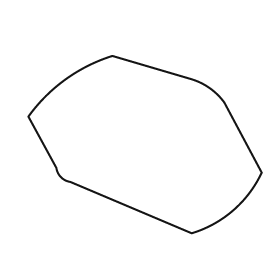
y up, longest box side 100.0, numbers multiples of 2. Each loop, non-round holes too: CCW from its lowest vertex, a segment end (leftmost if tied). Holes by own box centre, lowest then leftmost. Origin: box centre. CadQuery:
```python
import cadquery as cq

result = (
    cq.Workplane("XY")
    .moveTo(20.0, -38.0)
    .threePointArc((38.0, -28.0), (50.0, -12.0))
    .lineTo(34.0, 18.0)
    .threePointArc((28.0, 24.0), (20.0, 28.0))
    .lineTo(-14.0, 38.0)
    .threePointArc((-34.0, 28.0), (-50.0, 12.0))
    .lineTo(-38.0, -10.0)
    .threePointArc((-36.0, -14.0), (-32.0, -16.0))
    .close()
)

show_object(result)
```